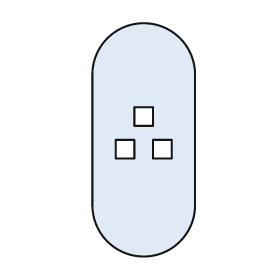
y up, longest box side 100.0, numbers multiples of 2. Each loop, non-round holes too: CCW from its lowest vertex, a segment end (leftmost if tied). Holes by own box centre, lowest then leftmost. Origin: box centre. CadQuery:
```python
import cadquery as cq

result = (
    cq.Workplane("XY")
    .moveTo(-22.0, -28.0)
    .threePointArc((0.0, -50.0), (22.0, -28.0))
    .lineTo(22.0, 28.0)
    .threePointArc((0.0, 50.0), (-22.0, 28.0))
    .close()
    .moveTo(-12.0, -8.0)
    .lineTo(-4.0, -8.0)
    .lineTo(-4.0, 0.0)
    .lineTo(-12.0, 0.0)
    .close()
    .moveTo(4.0, -8.0)
    .lineTo(12.0, -8.0)
    .lineTo(12.0, 0.0)
    .lineTo(4.0, 0.0)
    .close()
    .moveTo(-4.0, 6.0)
    .lineTo(4.0, 6.0)
    .lineTo(4.0, 14.0)
    .lineTo(-4.0, 14.0)
    .close()
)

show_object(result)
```